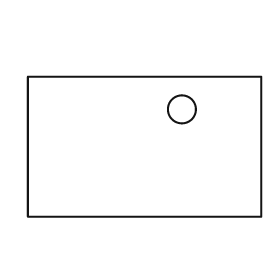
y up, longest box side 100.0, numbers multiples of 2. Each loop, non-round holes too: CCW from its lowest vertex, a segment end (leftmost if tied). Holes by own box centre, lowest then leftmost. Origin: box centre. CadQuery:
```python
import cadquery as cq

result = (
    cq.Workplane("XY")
    .moveTo(-50.0, -30.0)
    .lineTo(50.0, -30.0)
    .lineTo(50.0, 30.0)
    .lineTo(-50.0, 30.0)
    .close()
    .moveTo(16.0, 16.0)
    .circle(6.0)
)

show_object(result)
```